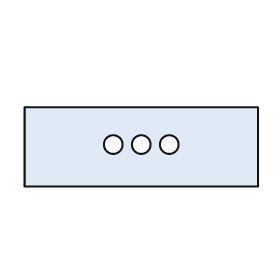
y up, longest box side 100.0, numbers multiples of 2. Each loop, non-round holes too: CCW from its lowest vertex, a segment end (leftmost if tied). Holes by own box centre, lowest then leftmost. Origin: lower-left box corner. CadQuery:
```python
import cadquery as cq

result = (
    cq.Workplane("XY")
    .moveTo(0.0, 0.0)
    .lineTo(100.0, 0.0)
    .lineTo(100.0, 34.0)
    .lineTo(0.0, 34.0)
    .close()
    .moveTo(38.0, 18.0)
    .circle(4.0)
    .moveTo(50.0, 18.0)
    .circle(4.0)
    .moveTo(62.0, 18.0)
    .circle(4.0)
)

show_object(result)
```